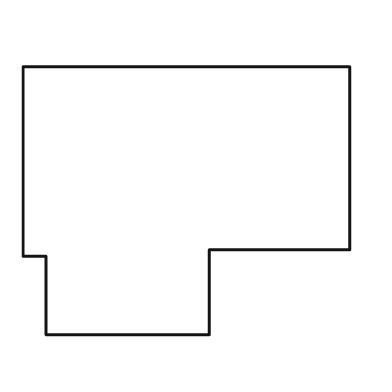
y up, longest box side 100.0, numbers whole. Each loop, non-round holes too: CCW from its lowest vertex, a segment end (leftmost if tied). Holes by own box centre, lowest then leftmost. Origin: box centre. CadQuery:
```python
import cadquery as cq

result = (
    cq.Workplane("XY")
    .moveTo(-43.0, -41.0)
    .lineTo(7.0, -41.0)
    .lineTo(7.0, -15.0)
    .lineTo(50.0, -15.0)
    .lineTo(50.0, 41.0)
    .lineTo(-50.0, 41.0)
    .lineTo(-50.0, -17.0)
    .lineTo(-43.0, -17.0)
    .close()
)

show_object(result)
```